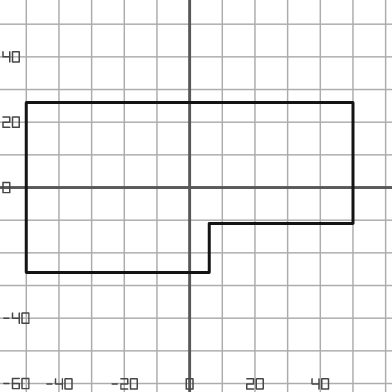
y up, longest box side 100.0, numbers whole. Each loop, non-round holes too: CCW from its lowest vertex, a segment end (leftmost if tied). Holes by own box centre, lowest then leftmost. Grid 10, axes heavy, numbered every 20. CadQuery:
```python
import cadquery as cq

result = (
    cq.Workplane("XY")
    .moveTo(-50.0, -26.0)
    .lineTo(6.0, -26.0)
    .lineTo(6.0, -11.0)
    .lineTo(50.0, -11.0)
    .lineTo(50.0, 26.0)
    .lineTo(-50.0, 26.0)
    .close()
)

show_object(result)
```